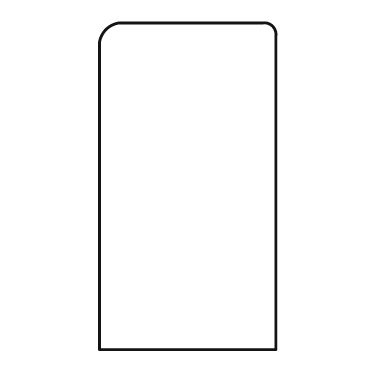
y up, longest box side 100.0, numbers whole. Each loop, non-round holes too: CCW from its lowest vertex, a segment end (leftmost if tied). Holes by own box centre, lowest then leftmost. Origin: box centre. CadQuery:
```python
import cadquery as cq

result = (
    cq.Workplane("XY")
    .moveTo(-27.0, -50.0)
    .lineTo(27.0, -50.0)
    .lineTo(27.0, 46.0)
    .threePointArc((26.0, 49.0), (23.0, 50.0))
    .lineTo(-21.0, 50.0)
    .threePointArc((-25.0, 48.0), (-27.0, 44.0))
    .close()
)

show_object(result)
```